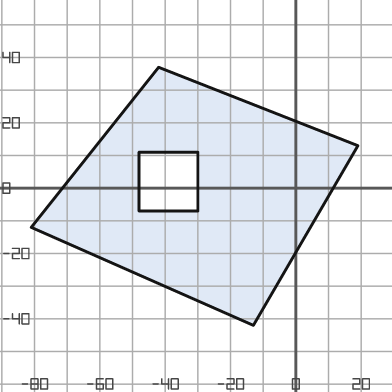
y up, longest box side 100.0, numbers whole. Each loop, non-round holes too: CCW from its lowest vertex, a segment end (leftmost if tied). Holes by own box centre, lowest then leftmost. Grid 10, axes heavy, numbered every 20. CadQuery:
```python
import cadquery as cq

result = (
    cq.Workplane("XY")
    .moveTo(-13.0, -42.0)
    .lineTo(19.0, 13.0)
    .lineTo(-42.0, 37.0)
    .lineTo(-81.0, -12.0)
    .close()
    .moveTo(-48.0, -7.0)
    .lineTo(-30.0, -7.0)
    .lineTo(-30.0, 11.0)
    .lineTo(-48.0, 11.0)
    .close()
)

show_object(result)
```